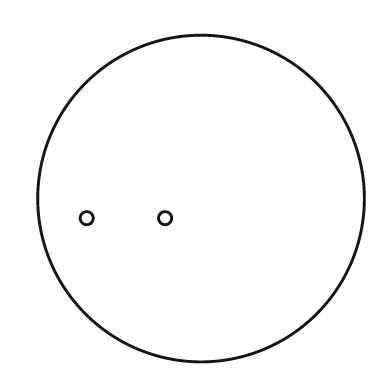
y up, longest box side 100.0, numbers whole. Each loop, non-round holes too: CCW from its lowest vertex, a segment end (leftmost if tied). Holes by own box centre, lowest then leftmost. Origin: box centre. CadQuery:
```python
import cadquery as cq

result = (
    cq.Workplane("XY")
    .moveTo(0.0, 0.0)
    .circle(50.0)
    .moveTo(-35.0, -6.0)
    .circle(2.0)
    .moveTo(-11.0, -6.0)
    .circle(2.0)
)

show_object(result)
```